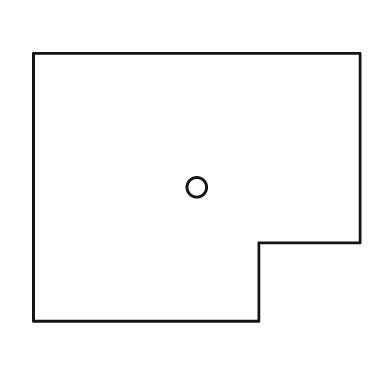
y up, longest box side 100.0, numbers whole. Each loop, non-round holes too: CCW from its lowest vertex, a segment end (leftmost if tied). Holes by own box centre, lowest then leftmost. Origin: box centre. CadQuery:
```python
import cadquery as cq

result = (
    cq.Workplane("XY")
    .moveTo(-50.0, -41.0)
    .lineTo(19.0, -41.0)
    .lineTo(19.0, -17.0)
    .lineTo(50.0, -17.0)
    .lineTo(50.0, 41.0)
    .lineTo(-50.0, 41.0)
    .close()
    .moveTo(0.0, 0.0)
    .circle(3.0)
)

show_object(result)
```